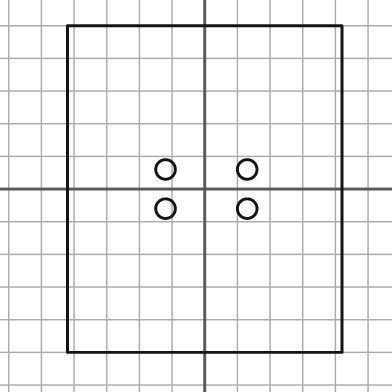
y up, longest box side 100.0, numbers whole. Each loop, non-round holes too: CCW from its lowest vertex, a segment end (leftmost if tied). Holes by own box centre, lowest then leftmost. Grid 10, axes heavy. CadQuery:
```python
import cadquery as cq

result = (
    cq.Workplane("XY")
    .moveTo(-42.0, -50.0)
    .lineTo(42.0, -50.0)
    .lineTo(42.0, 50.0)
    .lineTo(-42.0, 50.0)
    .close()
    .moveTo(-12.0, -6.0)
    .circle(3.0)
    .moveTo(13.0, -6.0)
    .circle(3.0)
    .moveTo(-12.0, 6.0)
    .circle(3.0)
    .moveTo(13.0, 6.0)
    .circle(3.0)
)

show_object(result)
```